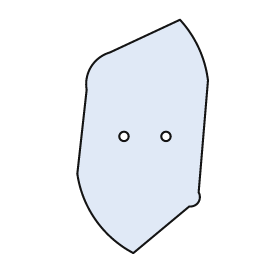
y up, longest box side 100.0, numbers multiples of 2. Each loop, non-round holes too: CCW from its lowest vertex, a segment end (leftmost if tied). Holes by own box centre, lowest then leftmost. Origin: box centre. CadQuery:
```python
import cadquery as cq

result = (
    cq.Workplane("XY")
    .moveTo(-4.0, -50.0)
    .lineTo(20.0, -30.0)
    .threePointArc((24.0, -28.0), (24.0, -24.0))
    .lineTo(28.0, 24.0)
    .threePointArc((24.0, 38.0), (16.0, 50.0))
    .lineTo(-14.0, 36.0)
    .threePointArc((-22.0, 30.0), (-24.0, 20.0))
    .lineTo(-28.0, -16.0)
    .threePointArc((-20.0, -36.0), (-4.0, -50.0))
    .close()
    .moveTo(-8.0, 0.0)
    .circle(2.0)
    .moveTo(10.0, 0.0)
    .circle(2.0)
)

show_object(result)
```